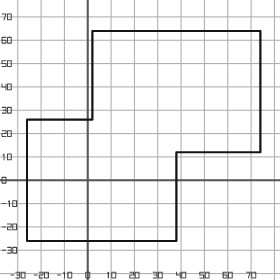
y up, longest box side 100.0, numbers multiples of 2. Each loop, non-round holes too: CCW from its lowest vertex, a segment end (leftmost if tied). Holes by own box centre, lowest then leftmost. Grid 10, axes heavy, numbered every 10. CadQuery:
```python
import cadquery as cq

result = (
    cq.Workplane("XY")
    .moveTo(-26.0, -26.0)
    .lineTo(38.0, -26.0)
    .lineTo(38.0, 12.0)
    .lineTo(74.0, 12.0)
    .lineTo(74.0, 64.0)
    .lineTo(2.0, 64.0)
    .lineTo(2.0, 26.0)
    .lineTo(-26.0, 26.0)
    .close()
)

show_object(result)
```